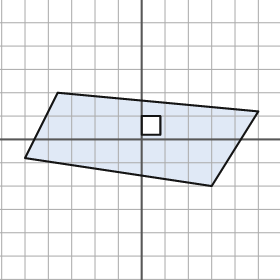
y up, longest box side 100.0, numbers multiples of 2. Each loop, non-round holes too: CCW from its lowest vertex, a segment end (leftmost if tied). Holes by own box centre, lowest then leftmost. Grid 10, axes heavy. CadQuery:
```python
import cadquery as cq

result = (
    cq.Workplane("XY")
    .moveTo(30.0, -20.0)
    .lineTo(50.0, 12.0)
    .lineTo(-36.0, 20.0)
    .lineTo(-50.0, -8.0)
    .close()
    .moveTo(0.0, 2.0)
    .lineTo(8.0, 2.0)
    .lineTo(8.0, 10.0)
    .lineTo(0.0, 10.0)
    .close()
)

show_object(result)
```